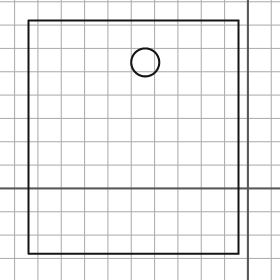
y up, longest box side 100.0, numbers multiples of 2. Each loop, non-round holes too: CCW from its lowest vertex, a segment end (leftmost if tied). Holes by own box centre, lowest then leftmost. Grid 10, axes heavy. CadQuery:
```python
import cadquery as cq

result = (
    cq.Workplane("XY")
    .moveTo(-94.0, -28.0)
    .lineTo(-4.0, -28.0)
    .lineTo(-4.0, 72.0)
    .lineTo(-94.0, 72.0)
    .close()
    .moveTo(-44.0, 54.0)
    .circle(6.0)
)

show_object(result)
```